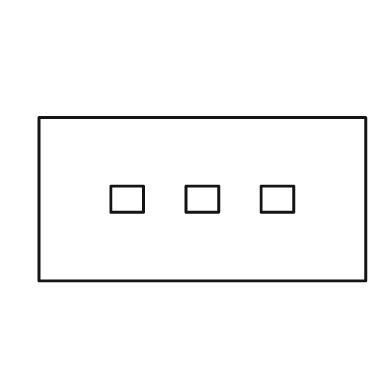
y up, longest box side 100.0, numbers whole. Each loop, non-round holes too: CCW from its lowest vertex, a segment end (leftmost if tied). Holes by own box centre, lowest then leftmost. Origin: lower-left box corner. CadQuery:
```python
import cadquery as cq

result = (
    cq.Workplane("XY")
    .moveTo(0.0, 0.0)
    .lineTo(100.0, 0.0)
    .lineTo(100.0, 50.0)
    .lineTo(0.0, 50.0)
    .close()
    .moveTo(22.0, 21.0)
    .lineTo(32.0, 21.0)
    .lineTo(32.0, 29.0)
    .lineTo(22.0, 29.0)
    .close()
    .moveTo(45.0, 21.0)
    .lineTo(55.0, 21.0)
    .lineTo(55.0, 29.0)
    .lineTo(45.0, 29.0)
    .close()
    .moveTo(68.0, 21.0)
    .lineTo(78.0, 21.0)
    .lineTo(78.0, 29.0)
    .lineTo(68.0, 29.0)
    .close()
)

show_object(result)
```